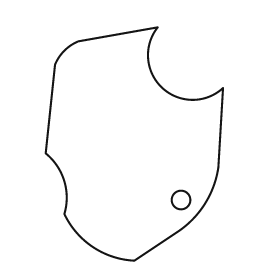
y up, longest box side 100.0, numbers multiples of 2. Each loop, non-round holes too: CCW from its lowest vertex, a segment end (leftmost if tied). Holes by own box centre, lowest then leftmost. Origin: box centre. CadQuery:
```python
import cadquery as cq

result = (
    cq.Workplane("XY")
    .moveTo(0.0, -50.0)
    .lineTo(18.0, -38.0)
    .threePointArc((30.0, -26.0), (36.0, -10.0))
    .lineTo(38.0, 24.0)
    .threePointArc((12.0, 24.0), (10.0, 50.0))
    .lineTo(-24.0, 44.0)
    .threePointArc((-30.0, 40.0), (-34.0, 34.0))
    .lineTo(-38.0, -4.0)
    .threePointArc((-30.0, -16.0), (-30.0, -30.0))
    .threePointArc((-18.0, -44.0), (0.0, -50.0))
    .close()
    .moveTo(20.0, -24.0)
    .circle(4.0)
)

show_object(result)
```